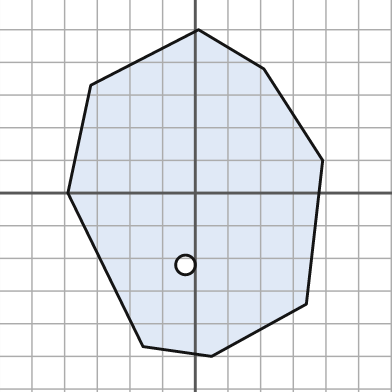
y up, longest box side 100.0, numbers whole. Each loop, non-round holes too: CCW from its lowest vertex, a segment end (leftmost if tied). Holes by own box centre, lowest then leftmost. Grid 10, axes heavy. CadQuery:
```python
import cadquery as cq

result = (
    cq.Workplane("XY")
    .moveTo(5.0, -50.0)
    .lineTo(34.0, -34.0)
    .lineTo(39.0, 10.0)
    .lineTo(21.0, 38.0)
    .lineTo(1.0, 50.0)
    .lineTo(-32.0, 33.0)
    .lineTo(-39.0, 0.0)
    .lineTo(-16.0, -47.0)
    .close()
    .moveTo(-3.0, -22.0)
    .circle(3.0)
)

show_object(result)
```